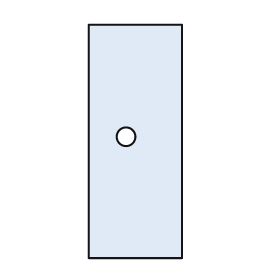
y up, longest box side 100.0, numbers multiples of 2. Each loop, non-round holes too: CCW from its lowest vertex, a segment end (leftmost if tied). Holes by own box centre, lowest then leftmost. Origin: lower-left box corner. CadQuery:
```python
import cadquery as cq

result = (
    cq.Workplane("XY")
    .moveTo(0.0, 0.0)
    .lineTo(40.0, 0.0)
    .lineTo(40.0, 100.0)
    .lineTo(0.0, 100.0)
    .close()
    .moveTo(16.0, 52.0)
    .circle(4.0)
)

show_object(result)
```